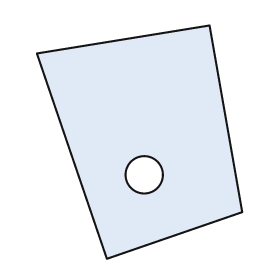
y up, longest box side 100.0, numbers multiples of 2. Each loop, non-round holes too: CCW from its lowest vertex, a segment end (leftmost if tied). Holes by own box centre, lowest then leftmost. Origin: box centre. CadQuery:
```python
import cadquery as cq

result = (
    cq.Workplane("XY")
    .moveTo(-14.0, -50.0)
    .lineTo(44.0, -30.0)
    .lineTo(30.0, 50.0)
    .lineTo(-44.0, 38.0)
    .close()
    .moveTo(2.0, -14.0)
    .circle(8.0)
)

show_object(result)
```